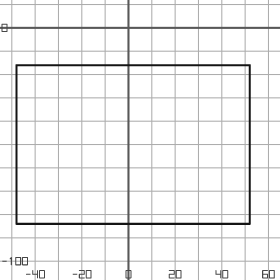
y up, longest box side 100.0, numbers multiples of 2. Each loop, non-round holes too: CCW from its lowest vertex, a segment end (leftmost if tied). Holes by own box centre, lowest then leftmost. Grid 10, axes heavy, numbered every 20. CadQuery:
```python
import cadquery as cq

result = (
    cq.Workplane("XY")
    .moveTo(-48.0, -84.0)
    .lineTo(52.0, -84.0)
    .lineTo(52.0, -16.0)
    .lineTo(-48.0, -16.0)
    .close()
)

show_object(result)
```